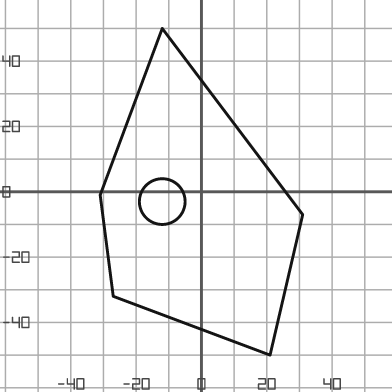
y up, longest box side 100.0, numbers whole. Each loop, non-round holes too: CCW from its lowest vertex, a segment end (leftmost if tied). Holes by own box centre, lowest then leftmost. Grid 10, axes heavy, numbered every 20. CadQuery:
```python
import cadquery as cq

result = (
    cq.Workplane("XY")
    .moveTo(21.0, -50.0)
    .lineTo(31.0, -7.0)
    .lineTo(-12.0, 50.0)
    .lineTo(-31.0, -1.0)
    .lineTo(-27.0, -32.0)
    .close()
    .moveTo(-12.0, -3.0)
    .circle(7.0)
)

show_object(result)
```